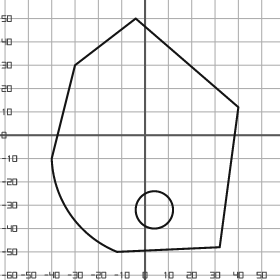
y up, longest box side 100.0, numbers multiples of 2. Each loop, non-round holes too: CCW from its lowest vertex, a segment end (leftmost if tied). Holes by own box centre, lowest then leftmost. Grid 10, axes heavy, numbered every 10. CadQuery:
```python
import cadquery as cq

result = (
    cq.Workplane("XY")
    .moveTo(-12.0, -50.0)
    .lineTo(32.0, -48.0)
    .lineTo(40.0, 12.0)
    .lineTo(-4.0, 50.0)
    .lineTo(-30.0, 30.0)
    .lineTo(-40.0, -10.0)
    .threePointArc((-32.0, -34.0), (-12.0, -50.0))
    .close()
    .moveTo(4.0, -32.0)
    .circle(8.0)
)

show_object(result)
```